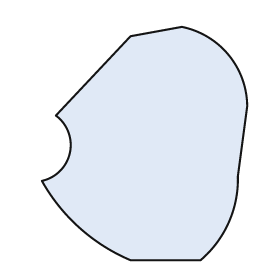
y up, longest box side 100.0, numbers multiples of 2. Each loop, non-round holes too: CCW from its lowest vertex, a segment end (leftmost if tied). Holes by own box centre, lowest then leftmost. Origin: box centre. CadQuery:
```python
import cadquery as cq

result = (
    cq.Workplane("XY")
    .moveTo(-6.0, -50.0)
    .lineTo(24.0, -50.0)
    .threePointArc((36.0, -34.0), (40.0, -14.0))
    .lineTo(44.0, 16.0)
    .threePointArc((36.0, 38.0), (16.0, 50.0))
    .lineTo(-6.0, 46.0)
    .lineTo(-38.0, 12.0)
    .threePointArc((-32.0, -4.0), (-44.0, -16.0))
    .threePointArc((-28.0, -36.0), (-6.0, -50.0))
    .close()
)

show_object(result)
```